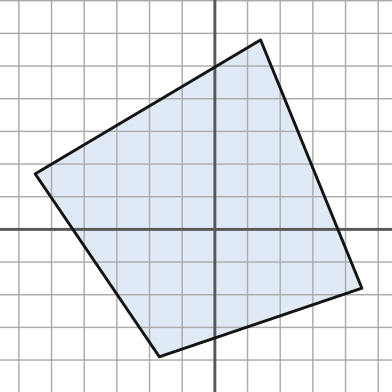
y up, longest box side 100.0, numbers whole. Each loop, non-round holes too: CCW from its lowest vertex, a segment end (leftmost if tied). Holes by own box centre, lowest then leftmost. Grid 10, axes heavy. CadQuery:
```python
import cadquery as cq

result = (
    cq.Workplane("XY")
    .moveTo(-17.0, -39.0)
    .lineTo(45.0, -18.0)
    .lineTo(14.0, 58.0)
    .lineTo(-55.0, 17.0)
    .close()
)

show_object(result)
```